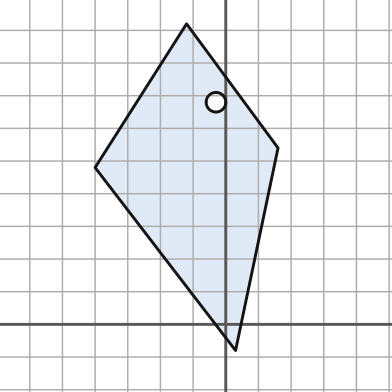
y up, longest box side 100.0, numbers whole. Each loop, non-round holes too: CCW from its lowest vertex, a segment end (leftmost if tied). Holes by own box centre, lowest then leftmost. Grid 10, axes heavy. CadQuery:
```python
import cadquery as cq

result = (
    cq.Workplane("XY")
    .moveTo(3.0, -8.0)
    .lineTo(16.0, 54.0)
    .lineTo(-12.0, 92.0)
    .lineTo(-40.0, 48.0)
    .close()
    .moveTo(-3.0, 68.0)
    .circle(3.0)
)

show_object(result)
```